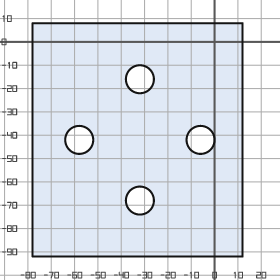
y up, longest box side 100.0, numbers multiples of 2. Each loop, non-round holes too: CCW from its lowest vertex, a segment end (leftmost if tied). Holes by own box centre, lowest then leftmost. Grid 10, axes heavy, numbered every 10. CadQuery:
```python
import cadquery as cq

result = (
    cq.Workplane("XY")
    .moveTo(-78.0, -92.0)
    .lineTo(12.0, -92.0)
    .lineTo(12.0, 8.0)
    .lineTo(-78.0, 8.0)
    .close()
    .moveTo(-32.0, -68.0)
    .circle(6.0)
    .moveTo(-58.0, -42.0)
    .circle(6.0)
    .moveTo(-6.0, -42.0)
    .circle(6.0)
    .moveTo(-32.0, -16.0)
    .circle(6.0)
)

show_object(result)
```